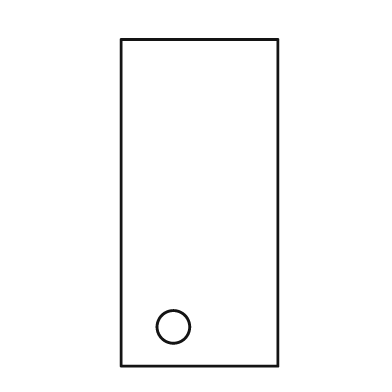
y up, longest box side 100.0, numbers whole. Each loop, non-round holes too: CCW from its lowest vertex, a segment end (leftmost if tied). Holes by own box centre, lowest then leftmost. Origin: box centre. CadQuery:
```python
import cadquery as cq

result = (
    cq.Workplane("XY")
    .moveTo(-24.0, -50.0)
    .lineTo(24.0, -50.0)
    .lineTo(24.0, 50.0)
    .lineTo(-24.0, 50.0)
    .close()
    .moveTo(-8.0, -38.0)
    .circle(5.0)
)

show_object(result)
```